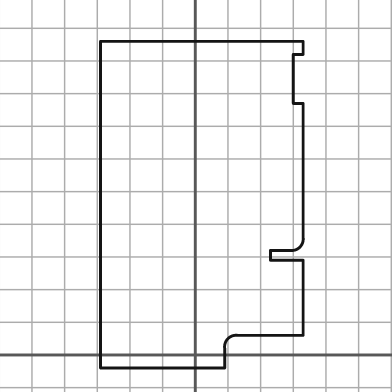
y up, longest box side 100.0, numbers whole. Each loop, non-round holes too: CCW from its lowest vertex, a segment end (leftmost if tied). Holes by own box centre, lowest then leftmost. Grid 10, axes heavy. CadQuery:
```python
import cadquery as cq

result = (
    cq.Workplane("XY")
    .moveTo(-29.0, -4.0)
    .lineTo(9.0, -4.0)
    .lineTo(9.0, 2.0)
    .threePointArc((10.0, 5.0), (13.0, 6.0))
    .lineTo(33.0, 6.0)
    .lineTo(33.0, 29.0)
    .lineTo(23.0, 29.0)
    .lineTo(23.0, 32.0)
    .lineTo(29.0, 32.0)
    .threePointArc((32.0, 33.0), (33.0, 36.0))
    .lineTo(33.0, 77.0)
    .lineTo(30.0, 77.0)
    .lineTo(30.0, 92.0)
    .lineTo(33.0, 92.0)
    .lineTo(33.0, 96.0)
    .lineTo(-29.0, 96.0)
    .close()
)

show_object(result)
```